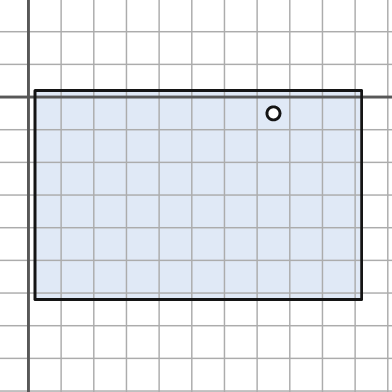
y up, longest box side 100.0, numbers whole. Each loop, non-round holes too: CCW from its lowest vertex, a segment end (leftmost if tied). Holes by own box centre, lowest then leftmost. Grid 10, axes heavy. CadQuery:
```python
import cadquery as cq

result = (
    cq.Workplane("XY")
    .moveTo(2.0, -62.0)
    .lineTo(102.0, -62.0)
    .lineTo(102.0, 2.0)
    .lineTo(2.0, 2.0)
    .close()
    .moveTo(75.0, -5.0)
    .circle(2.0)
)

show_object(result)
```